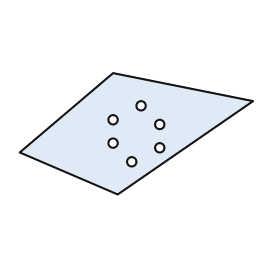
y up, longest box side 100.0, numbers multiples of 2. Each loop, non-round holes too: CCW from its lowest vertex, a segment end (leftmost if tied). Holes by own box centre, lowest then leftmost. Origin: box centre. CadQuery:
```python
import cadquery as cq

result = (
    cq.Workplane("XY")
    .moveTo(-8.0, -26.0)
    .lineTo(50.0, 14.0)
    .lineTo(-10.0, 26.0)
    .lineTo(-50.0, -8.0)
    .close()
    .moveTo(-2.0, -12.0)
    .circle(2.0)
    .moveTo(10.0, -6.0)
    .circle(2.0)
    .moveTo(-10.0, -4.0)
    .circle(2.0)
    .moveTo(10.0, 4.0)
    .circle(2.0)
    .moveTo(-10.0, 6.0)
    .circle(2.0)
    .moveTo(2.0, 12.0)
    .circle(2.0)
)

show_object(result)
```